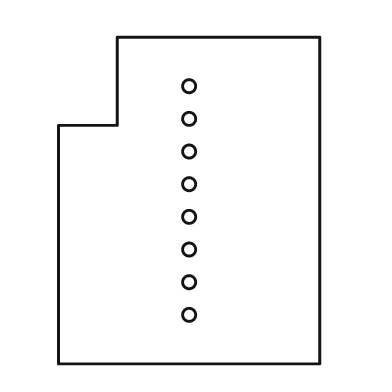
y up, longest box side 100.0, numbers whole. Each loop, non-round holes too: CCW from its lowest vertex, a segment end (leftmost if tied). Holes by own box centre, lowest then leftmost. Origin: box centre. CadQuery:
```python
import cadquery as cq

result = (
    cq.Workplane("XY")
    .moveTo(-40.0, -50.0)
    .lineTo(40.0, -50.0)
    .lineTo(40.0, 50.0)
    .lineTo(-22.0, 50.0)
    .lineTo(-22.0, 23.0)
    .lineTo(-40.0, 23.0)
    .close()
    .moveTo(0.0, -35.0)
    .circle(2.0)
    .moveTo(0.0, -25.0)
    .circle(2.0)
    .moveTo(0.0, -15.0)
    .circle(2.0)
    .moveTo(0.0, -5.0)
    .circle(2.0)
    .moveTo(0.0, 5.0)
    .circle(2.0)
    .moveTo(0.0, 15.0)
    .circle(2.0)
    .moveTo(0.0, 25.0)
    .circle(2.0)
    .moveTo(0.0, 35.0)
    .circle(2.0)
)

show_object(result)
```